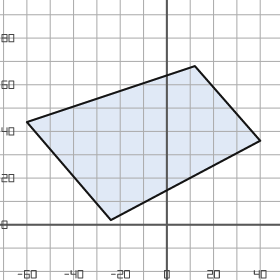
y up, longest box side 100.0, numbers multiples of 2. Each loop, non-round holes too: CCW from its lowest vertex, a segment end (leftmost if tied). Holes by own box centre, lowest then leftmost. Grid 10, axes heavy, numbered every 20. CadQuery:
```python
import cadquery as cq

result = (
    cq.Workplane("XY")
    .moveTo(-24.0, 2.0)
    .lineTo(40.0, 36.0)
    .lineTo(12.0, 68.0)
    .lineTo(-60.0, 44.0)
    .close()
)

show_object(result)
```